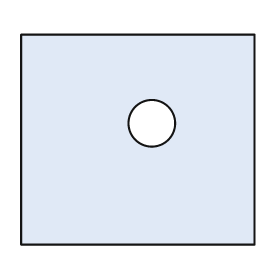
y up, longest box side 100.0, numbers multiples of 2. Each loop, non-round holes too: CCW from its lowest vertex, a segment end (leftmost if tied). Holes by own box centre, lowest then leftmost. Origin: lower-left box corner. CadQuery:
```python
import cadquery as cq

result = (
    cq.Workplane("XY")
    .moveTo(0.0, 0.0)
    .lineTo(100.0, 0.0)
    .lineTo(100.0, 90.0)
    .lineTo(0.0, 90.0)
    .close()
    .moveTo(56.0, 52.0)
    .circle(10.0)
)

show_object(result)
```